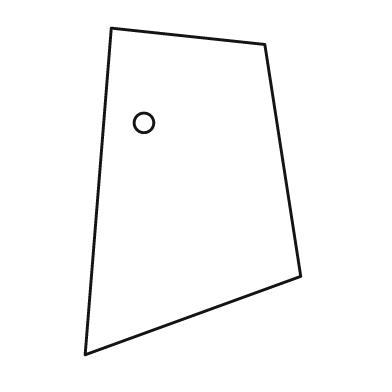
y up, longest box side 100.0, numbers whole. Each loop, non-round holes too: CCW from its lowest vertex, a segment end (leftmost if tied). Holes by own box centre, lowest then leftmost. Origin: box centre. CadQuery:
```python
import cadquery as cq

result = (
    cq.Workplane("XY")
    .moveTo(-33.0, -50.0)
    .lineTo(33.0, -26.0)
    .lineTo(22.0, 45.0)
    .lineTo(-25.0, 50.0)
    .close()
    .moveTo(-15.0, 21.0)
    .circle(3.0)
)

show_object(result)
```